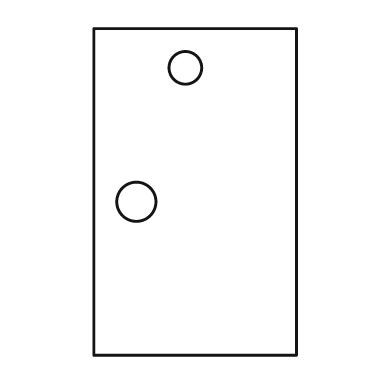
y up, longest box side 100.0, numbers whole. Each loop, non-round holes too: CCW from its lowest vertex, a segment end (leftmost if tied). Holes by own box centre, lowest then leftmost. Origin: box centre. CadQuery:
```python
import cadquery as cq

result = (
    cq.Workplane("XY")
    .moveTo(-31.0, -50.0)
    .lineTo(31.0, -50.0)
    .lineTo(31.0, 50.0)
    .lineTo(-31.0, 50.0)
    .close()
    .moveTo(-18.0, -3.0)
    .circle(6.0)
    .moveTo(-3.0, 38.0)
    .circle(5.0)
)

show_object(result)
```